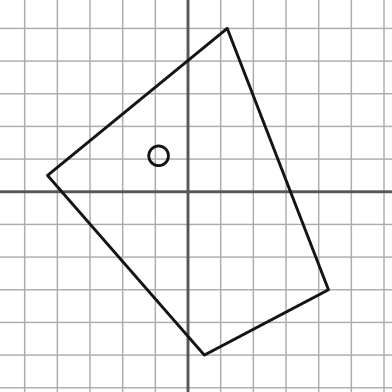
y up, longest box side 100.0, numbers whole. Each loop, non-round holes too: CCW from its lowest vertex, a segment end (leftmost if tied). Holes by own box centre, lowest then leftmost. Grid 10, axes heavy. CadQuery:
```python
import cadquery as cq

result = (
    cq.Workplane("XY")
    .moveTo(5.0, -50.0)
    .lineTo(43.0, -30.0)
    .lineTo(12.0, 50.0)
    .lineTo(-43.0, 5.0)
    .close()
    .moveTo(-9.0, 11.0)
    .circle(3.0)
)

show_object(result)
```